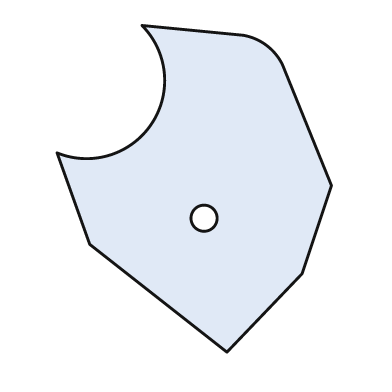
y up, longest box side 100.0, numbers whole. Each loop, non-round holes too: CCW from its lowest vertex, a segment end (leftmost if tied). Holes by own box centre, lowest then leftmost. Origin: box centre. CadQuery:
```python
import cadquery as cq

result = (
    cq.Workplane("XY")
    .moveTo(10.0, -50.0)
    .lineTo(33.0, -26.0)
    .lineTo(42.0, 1.0)
    .lineTo(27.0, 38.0)
    .threePointArc((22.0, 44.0), (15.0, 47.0))
    .lineTo(-16.0, 50.0)
    .threePointArc((-13.0, 20.0), (-42.0, 11.0))
    .lineTo(-32.0, -17.0)
    .close()
    .moveTo(3.0, -9.0)
    .circle(4.0)
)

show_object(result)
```